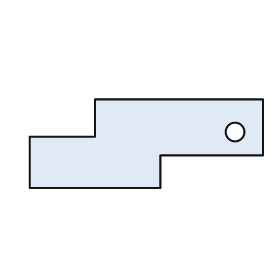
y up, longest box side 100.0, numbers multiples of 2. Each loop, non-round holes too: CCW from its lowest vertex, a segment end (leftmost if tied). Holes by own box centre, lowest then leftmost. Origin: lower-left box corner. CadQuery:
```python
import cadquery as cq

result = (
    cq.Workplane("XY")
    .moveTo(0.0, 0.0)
    .lineTo(56.0, 0.0)
    .lineTo(56.0, 14.0)
    .lineTo(100.0, 14.0)
    .lineTo(100.0, 38.0)
    .lineTo(28.0, 38.0)
    .lineTo(28.0, 22.0)
    .lineTo(0.0, 22.0)
    .close()
    .moveTo(88.0, 24.0)
    .circle(4.0)
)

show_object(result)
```